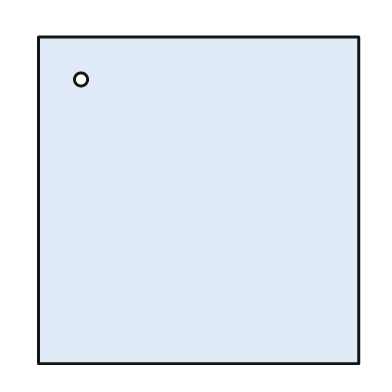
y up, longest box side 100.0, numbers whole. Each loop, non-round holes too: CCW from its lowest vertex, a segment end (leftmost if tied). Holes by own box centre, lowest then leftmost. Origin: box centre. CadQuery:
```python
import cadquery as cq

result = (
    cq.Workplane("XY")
    .moveTo(-49.0, -50.0)
    .lineTo(49.0, -50.0)
    .lineTo(49.0, 50.0)
    .lineTo(-49.0, 50.0)
    .close()
    .moveTo(-36.0, 37.0)
    .circle(2.0)
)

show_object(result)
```